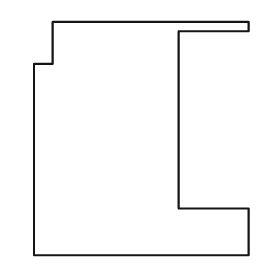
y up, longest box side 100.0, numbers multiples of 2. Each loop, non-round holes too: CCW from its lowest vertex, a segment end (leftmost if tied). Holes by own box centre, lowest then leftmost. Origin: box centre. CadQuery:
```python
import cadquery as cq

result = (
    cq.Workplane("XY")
    .moveTo(-46.0, -50.0)
    .lineTo(46.0, -50.0)
    .lineTo(46.0, -30.0)
    .lineTo(16.0, -30.0)
    .lineTo(16.0, 46.0)
    .lineTo(46.0, 46.0)
    .lineTo(46.0, 50.0)
    .lineTo(-38.0, 50.0)
    .lineTo(-38.0, 32.0)
    .lineTo(-46.0, 32.0)
    .close()
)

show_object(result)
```